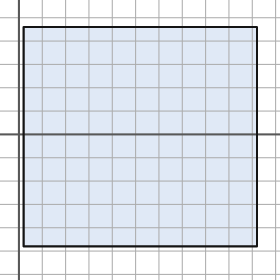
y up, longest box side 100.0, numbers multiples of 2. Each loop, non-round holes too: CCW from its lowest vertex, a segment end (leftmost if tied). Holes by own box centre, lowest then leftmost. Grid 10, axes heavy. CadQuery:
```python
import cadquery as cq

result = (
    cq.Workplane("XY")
    .moveTo(2.0, -48.0)
    .lineTo(102.0, -48.0)
    .lineTo(102.0, 46.0)
    .lineTo(2.0, 46.0)
    .close()
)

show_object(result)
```